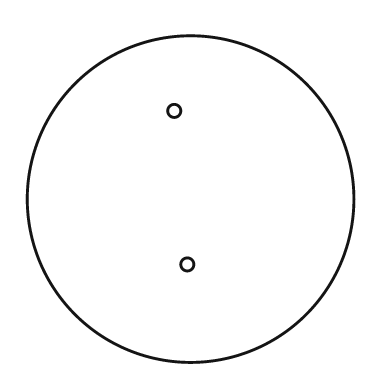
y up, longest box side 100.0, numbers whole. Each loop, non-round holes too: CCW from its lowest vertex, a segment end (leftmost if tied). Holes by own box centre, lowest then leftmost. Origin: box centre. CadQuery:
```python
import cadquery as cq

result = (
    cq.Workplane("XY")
    .moveTo(0.0, 0.0)
    .circle(50.0)
    .moveTo(-1.0, -20.0)
    .circle(2.0)
    .moveTo(-5.0, 27.0)
    .circle(2.0)
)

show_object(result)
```